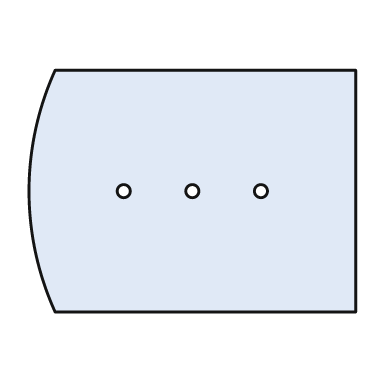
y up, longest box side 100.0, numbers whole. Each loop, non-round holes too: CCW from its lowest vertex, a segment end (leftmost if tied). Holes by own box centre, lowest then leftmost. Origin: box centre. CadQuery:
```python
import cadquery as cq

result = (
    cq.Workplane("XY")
    .moveTo(-42.0, -37.0)
    .lineTo(50.0, -37.0)
    .lineTo(50.0, 37.0)
    .lineTo(-42.0, 37.0)
    .threePointArc((-50.0, 0.0), (-42.0, -37.0))
    .close()
    .moveTo(-21.0, 0.0)
    .circle(2.0)
    .moveTo(0.0, 0.0)
    .circle(2.0)
    .moveTo(21.0, 0.0)
    .circle(2.0)
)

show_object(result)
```